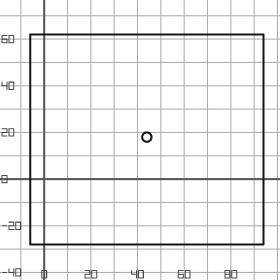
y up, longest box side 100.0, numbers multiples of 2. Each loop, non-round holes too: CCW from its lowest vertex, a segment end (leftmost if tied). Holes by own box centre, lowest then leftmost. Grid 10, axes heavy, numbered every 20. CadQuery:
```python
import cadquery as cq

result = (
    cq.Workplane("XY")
    .moveTo(-6.0, -28.0)
    .lineTo(94.0, -28.0)
    .lineTo(94.0, 62.0)
    .lineTo(-6.0, 62.0)
    .close()
    .moveTo(44.0, 18.0)
    .circle(2.0)
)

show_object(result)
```